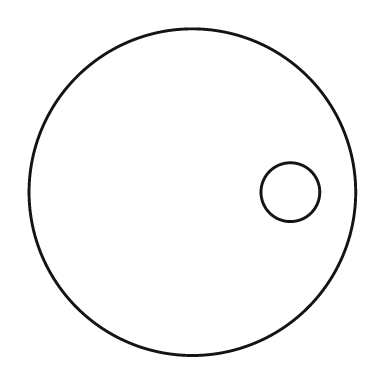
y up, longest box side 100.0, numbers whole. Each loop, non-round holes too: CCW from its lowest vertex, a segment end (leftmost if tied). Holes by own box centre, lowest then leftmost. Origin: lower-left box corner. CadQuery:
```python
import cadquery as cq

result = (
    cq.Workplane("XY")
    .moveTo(50.0, 50.0)
    .circle(50.0)
    .moveTo(80.0, 50.0)
    .circle(9.0)
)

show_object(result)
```